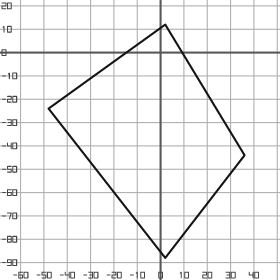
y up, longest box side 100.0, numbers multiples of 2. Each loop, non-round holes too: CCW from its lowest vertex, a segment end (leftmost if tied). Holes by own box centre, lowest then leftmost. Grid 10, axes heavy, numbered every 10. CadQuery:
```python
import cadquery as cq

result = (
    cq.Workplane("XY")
    .moveTo(2.0, -88.0)
    .lineTo(36.0, -44.0)
    .lineTo(2.0, 12.0)
    .lineTo(-48.0, -24.0)
    .close()
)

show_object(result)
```